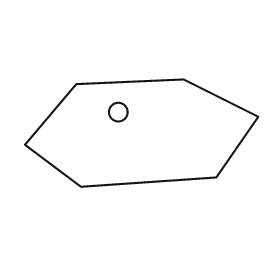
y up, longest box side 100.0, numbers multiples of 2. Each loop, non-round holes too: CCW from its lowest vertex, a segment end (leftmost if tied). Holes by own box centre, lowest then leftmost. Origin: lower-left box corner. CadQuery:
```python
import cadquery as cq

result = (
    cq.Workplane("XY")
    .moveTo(24.0, 0.0)
    .lineTo(82.0, 4.0)
    .lineTo(100.0, 30.0)
    .lineTo(68.0, 46.0)
    .lineTo(22.0, 44.0)
    .lineTo(0.0, 18.0)
    .close()
    .moveTo(40.0, 32.0)
    .circle(4.0)
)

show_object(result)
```